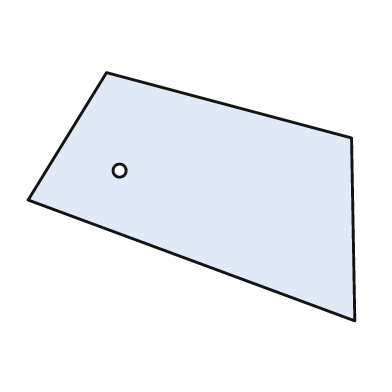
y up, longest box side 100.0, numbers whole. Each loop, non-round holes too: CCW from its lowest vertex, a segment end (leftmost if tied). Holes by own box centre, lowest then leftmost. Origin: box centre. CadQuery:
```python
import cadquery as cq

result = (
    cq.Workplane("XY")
    .moveTo(50.0, -38.0)
    .lineTo(49.0, 18.0)
    .lineTo(-26.0, 38.0)
    .lineTo(-50.0, -1.0)
    .close()
    .moveTo(-22.0, 8.0)
    .circle(2.0)
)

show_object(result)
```